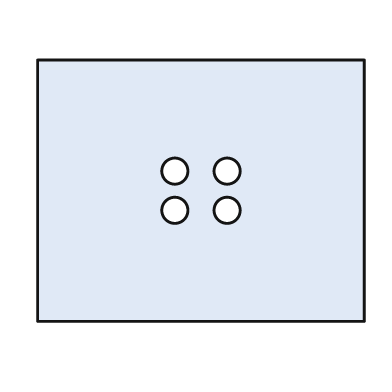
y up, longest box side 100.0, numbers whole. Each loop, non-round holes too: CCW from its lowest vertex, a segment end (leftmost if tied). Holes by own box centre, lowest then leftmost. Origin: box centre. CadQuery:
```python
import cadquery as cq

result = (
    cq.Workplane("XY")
    .moveTo(-50.0, -40.0)
    .lineTo(50.0, -40.0)
    .lineTo(50.0, 40.0)
    .lineTo(-50.0, 40.0)
    .close()
    .moveTo(-8.0, -6.0)
    .circle(4.0)
    .moveTo(8.0, -6.0)
    .circle(4.0)
    .moveTo(-8.0, 6.0)
    .circle(4.0)
    .moveTo(8.0, 6.0)
    .circle(4.0)
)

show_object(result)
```